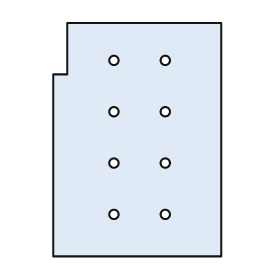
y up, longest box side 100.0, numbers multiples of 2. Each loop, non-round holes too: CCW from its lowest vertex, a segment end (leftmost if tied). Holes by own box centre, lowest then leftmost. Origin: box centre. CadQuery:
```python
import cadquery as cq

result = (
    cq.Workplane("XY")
    .moveTo(-36.0, -50.0)
    .lineTo(36.0, -50.0)
    .lineTo(36.0, 50.0)
    .lineTo(-30.0, 50.0)
    .lineTo(-30.0, 28.0)
    .lineTo(-36.0, 28.0)
    .close()
    .moveTo(-10.0, -32.0)
    .circle(2.0)
    .moveTo(12.0, -32.0)
    .circle(2.0)
    .moveTo(-10.0, -10.0)
    .circle(2.0)
    .moveTo(12.0, -10.0)
    .circle(2.0)
    .moveTo(-10.0, 12.0)
    .circle(2.0)
    .moveTo(12.0, 12.0)
    .circle(2.0)
    .moveTo(-10.0, 34.0)
    .circle(2.0)
    .moveTo(12.0, 34.0)
    .circle(2.0)
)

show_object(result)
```